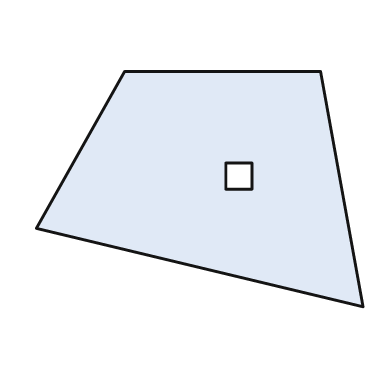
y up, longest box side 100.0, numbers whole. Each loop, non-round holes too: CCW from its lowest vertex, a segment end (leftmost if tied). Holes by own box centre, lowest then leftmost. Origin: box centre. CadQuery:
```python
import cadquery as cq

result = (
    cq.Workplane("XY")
    .moveTo(50.0, -36.0)
    .lineTo(37.0, 36.0)
    .lineTo(-23.0, 36.0)
    .lineTo(-50.0, -12.0)
    .close()
    .moveTo(8.0, 0.0)
    .lineTo(16.0, 0.0)
    .lineTo(16.0, 8.0)
    .lineTo(8.0, 8.0)
    .close()
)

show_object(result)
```